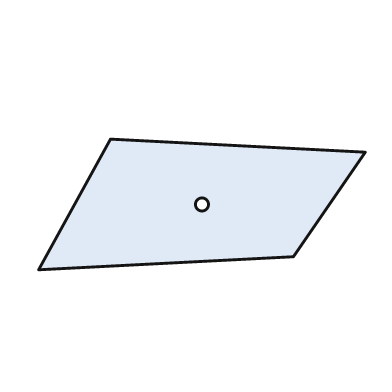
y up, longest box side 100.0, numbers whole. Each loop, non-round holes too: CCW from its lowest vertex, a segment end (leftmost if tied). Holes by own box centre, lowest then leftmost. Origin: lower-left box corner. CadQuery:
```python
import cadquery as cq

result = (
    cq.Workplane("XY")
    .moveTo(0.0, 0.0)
    .lineTo(78.0, 4.0)
    .lineTo(100.0, 36.0)
    .lineTo(22.0, 40.0)
    .close()
    .moveTo(50.0, 20.0)
    .circle(2.0)
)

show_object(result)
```